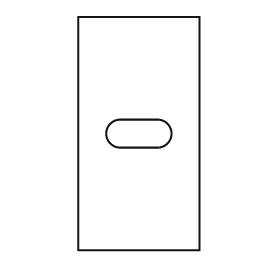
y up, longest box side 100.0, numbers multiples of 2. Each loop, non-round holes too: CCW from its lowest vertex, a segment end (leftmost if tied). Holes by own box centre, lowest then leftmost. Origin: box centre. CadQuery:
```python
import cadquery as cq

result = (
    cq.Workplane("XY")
    .moveTo(-26.0, -50.0)
    .lineTo(26.0, -50.0)
    .lineTo(26.0, 50.0)
    .lineTo(-26.0, 50.0)
    .close()
    .moveTo(-8.0, -6.0)
    .lineTo(8.0, -6.0)
    .threePointArc((14.0, 0.0), (8.0, 6.0))
    .lineTo(-8.0, 6.0)
    .threePointArc((-14.0, 0.0), (-8.0, -6.0))
    .close()
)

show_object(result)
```